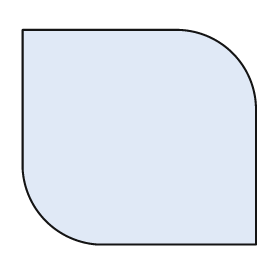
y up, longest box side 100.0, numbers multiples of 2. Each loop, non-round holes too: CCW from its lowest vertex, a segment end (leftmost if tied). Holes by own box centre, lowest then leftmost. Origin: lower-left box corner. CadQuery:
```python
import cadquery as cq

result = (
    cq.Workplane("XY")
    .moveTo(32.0, 0.0)
    .lineTo(100.0, 0.0)
    .lineTo(100.0, 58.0)
    .threePointArc((90.0, 82.0), (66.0, 92.0))
    .lineTo(0.0, 92.0)
    .lineTo(0.0, 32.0)
    .threePointArc((10.0, 10.0), (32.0, 0.0))
    .close()
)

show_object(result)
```